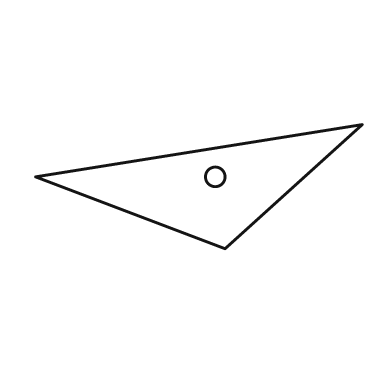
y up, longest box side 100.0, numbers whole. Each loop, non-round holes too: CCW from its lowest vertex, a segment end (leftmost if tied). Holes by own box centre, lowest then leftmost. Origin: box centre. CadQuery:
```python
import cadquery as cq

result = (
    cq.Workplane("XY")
    .moveTo(8.0, -19.0)
    .lineTo(50.0, 19.0)
    .lineTo(-50.0, 3.0)
    .close()
    .moveTo(5.0, 3.0)
    .circle(3.0)
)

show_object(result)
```